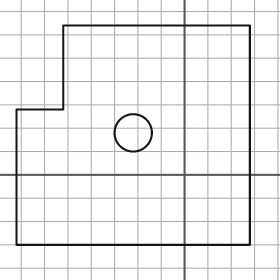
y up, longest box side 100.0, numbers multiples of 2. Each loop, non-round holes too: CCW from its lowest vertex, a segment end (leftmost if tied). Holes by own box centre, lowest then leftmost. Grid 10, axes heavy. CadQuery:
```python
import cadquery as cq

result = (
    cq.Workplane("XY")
    .moveTo(-72.0, -30.0)
    .lineTo(28.0, -30.0)
    .lineTo(28.0, 64.0)
    .lineTo(-52.0, 64.0)
    .lineTo(-52.0, 28.0)
    .lineTo(-72.0, 28.0)
    .close()
    .moveTo(-22.0, 18.0)
    .circle(8.0)
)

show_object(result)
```